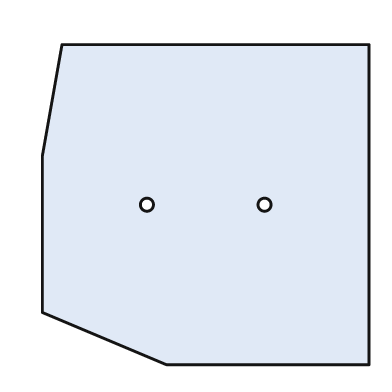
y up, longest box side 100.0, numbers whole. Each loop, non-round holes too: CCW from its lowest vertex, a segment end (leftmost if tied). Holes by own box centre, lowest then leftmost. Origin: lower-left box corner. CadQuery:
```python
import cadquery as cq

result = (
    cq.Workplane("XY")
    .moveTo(38.0, 0.0)
    .lineTo(100.0, 0.0)
    .lineTo(100.0, 98.0)
    .lineTo(6.0, 98.0)
    .lineTo(0.0, 64.0)
    .lineTo(0.0, 16.0)
    .close()
    .moveTo(32.0, 49.0)
    .circle(2.0)
    .moveTo(68.0, 49.0)
    .circle(2.0)
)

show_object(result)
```